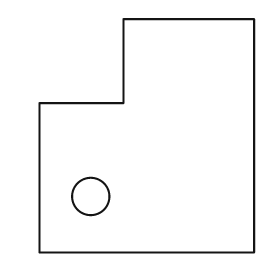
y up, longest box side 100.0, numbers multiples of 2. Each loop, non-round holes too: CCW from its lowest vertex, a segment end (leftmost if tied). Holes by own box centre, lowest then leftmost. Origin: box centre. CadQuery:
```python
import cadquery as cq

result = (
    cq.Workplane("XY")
    .moveTo(-46.0, -50.0)
    .lineTo(46.0, -50.0)
    .lineTo(46.0, 50.0)
    .lineTo(-10.0, 50.0)
    .lineTo(-10.0, 14.0)
    .lineTo(-46.0, 14.0)
    .close()
    .moveTo(-24.0, -26.0)
    .circle(8.0)
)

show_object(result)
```